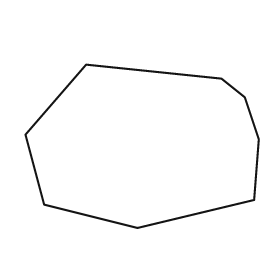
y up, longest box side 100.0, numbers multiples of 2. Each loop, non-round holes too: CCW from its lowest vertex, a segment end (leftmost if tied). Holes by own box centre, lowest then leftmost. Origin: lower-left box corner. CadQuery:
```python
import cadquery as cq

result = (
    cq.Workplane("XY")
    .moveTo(48.0, 0.0)
    .lineTo(98.0, 12.0)
    .lineTo(100.0, 38.0)
    .lineTo(94.0, 56.0)
    .lineTo(84.0, 64.0)
    .lineTo(26.0, 70.0)
    .lineTo(0.0, 40.0)
    .lineTo(8.0, 10.0)
    .close()
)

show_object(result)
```